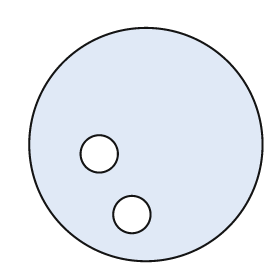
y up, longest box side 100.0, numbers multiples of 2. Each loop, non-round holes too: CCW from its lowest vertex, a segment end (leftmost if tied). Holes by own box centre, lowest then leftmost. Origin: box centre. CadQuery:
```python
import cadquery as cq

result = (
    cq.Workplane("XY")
    .moveTo(0.0, 0.0)
    .circle(50.0)
    .moveTo(-6.0, -30.0)
    .circle(8.0)
    .moveTo(-20.0, -4.0)
    .circle(8.0)
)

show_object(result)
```